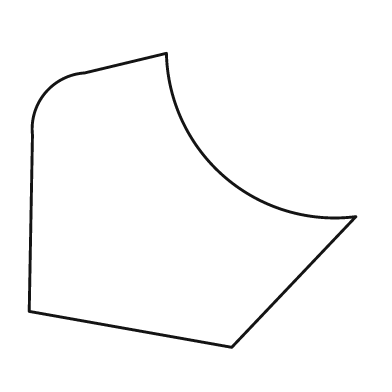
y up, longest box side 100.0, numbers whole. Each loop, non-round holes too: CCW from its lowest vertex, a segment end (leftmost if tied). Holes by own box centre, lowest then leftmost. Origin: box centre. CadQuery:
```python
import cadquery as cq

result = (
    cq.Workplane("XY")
    .moveTo(12.0, -45.0)
    .lineTo(50.0, -5.0)
    .threePointArc((10.0, 7.0), (-8.0, 45.0))
    .lineTo(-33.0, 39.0)
    .threePointArc((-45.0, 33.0), (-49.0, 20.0))
    .lineTo(-50.0, -34.0)
    .close()
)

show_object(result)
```